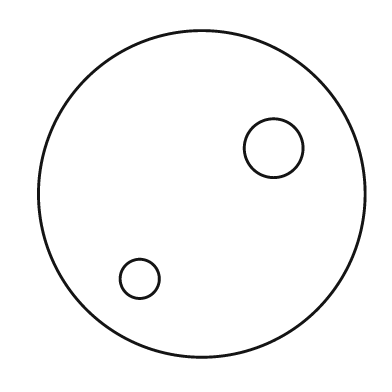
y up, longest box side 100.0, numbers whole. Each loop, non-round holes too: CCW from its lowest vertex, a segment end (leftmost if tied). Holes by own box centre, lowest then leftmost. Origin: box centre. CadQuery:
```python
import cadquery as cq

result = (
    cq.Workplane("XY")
    .moveTo(0.0, 0.0)
    .circle(50.0)
    .moveTo(-19.0, -26.0)
    .circle(6.0)
    .moveTo(22.0, 14.0)
    .circle(9.0)
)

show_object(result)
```